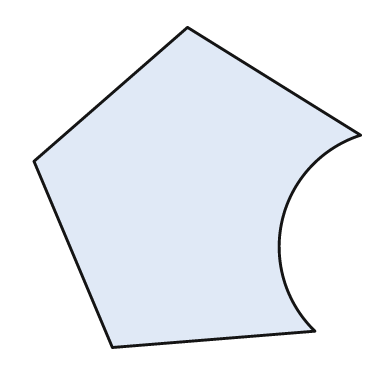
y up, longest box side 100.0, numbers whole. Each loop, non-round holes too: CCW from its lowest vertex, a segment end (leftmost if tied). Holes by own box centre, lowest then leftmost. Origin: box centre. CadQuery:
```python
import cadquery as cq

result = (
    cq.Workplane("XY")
    .moveTo(-26.0, -49.0)
    .lineTo(36.0, -44.0)
    .threePointArc((26.0, -10.0), (50.0, 16.0))
    .lineTo(-3.0, 49.0)
    .lineTo(-50.0, 8.0)
    .close()
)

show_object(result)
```